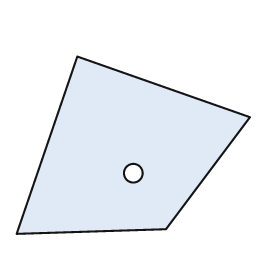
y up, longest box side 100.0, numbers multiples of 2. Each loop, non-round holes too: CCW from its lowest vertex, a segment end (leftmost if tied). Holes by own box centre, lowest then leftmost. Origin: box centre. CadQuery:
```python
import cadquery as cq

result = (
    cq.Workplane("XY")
    .moveTo(-50.0, -38.0)
    .lineTo(14.0, -36.0)
    .lineTo(50.0, 12.0)
    .lineTo(-24.0, 38.0)
    .close()
    .moveTo(0.0, -12.0)
    .circle(4.0)
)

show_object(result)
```